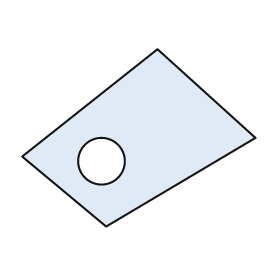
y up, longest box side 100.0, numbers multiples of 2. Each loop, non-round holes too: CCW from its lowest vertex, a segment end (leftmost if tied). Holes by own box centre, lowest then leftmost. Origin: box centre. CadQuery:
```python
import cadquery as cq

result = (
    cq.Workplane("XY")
    .moveTo(-14.0, -38.0)
    .lineTo(50.0, 0.0)
    .lineTo(8.0, 38.0)
    .lineTo(-50.0, -8.0)
    .close()
    .moveTo(-16.0, -10.0)
    .circle(10.0)
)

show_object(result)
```